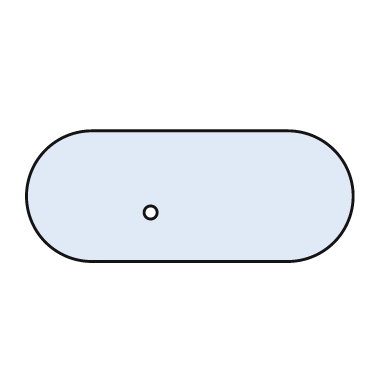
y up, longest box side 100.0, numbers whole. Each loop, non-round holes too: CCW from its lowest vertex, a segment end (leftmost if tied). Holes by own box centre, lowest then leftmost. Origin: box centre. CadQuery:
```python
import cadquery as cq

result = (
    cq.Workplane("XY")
    .moveTo(-30.0, -20.0)
    .lineTo(30.0, -20.0)
    .threePointArc((50.0, 0.0), (30.0, 20.0))
    .lineTo(-30.0, 20.0)
    .threePointArc((-50.0, 0.0), (-30.0, -20.0))
    .close()
    .moveTo(-12.0, -5.0)
    .circle(2.0)
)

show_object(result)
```